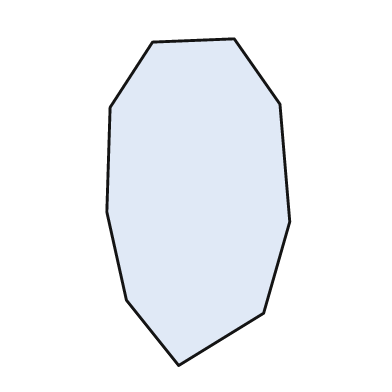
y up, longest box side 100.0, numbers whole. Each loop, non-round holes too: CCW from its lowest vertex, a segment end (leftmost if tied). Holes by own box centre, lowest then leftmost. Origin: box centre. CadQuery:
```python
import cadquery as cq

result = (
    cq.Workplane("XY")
    .moveTo(-6.0, -50.0)
    .lineTo(20.0, -34.0)
    .lineTo(28.0, -6.0)
    .lineTo(25.0, 30.0)
    .lineTo(11.0, 50.0)
    .lineTo(-14.0, 49.0)
    .lineTo(-27.0, 29.0)
    .lineTo(-28.0, -3.0)
    .lineTo(-22.0, -30.0)
    .close()
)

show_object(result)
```